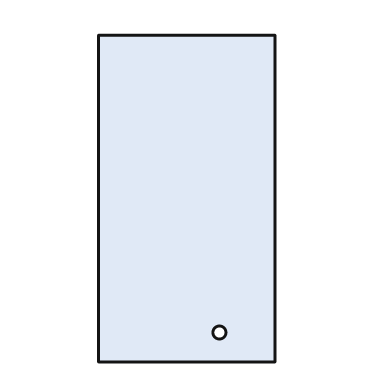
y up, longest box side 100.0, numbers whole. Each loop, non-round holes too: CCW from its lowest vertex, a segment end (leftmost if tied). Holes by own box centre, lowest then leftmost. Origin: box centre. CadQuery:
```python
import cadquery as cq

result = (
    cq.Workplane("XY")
    .moveTo(-27.0, -50.0)
    .lineTo(27.0, -50.0)
    .lineTo(27.0, 50.0)
    .lineTo(-27.0, 50.0)
    .close()
    .moveTo(10.0, -41.0)
    .circle(2.0)
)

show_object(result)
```